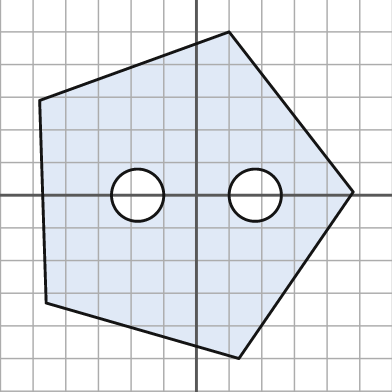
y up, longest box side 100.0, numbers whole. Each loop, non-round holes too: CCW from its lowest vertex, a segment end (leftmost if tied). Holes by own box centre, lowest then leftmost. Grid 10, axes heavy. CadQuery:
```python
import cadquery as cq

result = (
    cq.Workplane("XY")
    .moveTo(13.0, -50.0)
    .lineTo(48.0, 1.0)
    .lineTo(10.0, 50.0)
    .lineTo(-48.0, 29.0)
    .lineTo(-46.0, -33.0)
    .close()
    .moveTo(-18.0, 0.0)
    .circle(8.0)
    .moveTo(18.0, 0.0)
    .circle(8.0)
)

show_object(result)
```